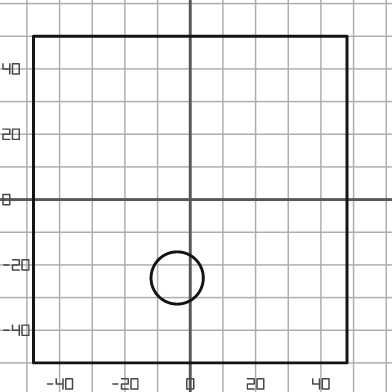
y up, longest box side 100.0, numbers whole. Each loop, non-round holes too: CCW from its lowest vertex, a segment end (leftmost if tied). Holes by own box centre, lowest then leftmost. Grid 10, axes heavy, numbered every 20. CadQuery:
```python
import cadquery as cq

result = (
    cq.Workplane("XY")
    .moveTo(-48.0, -50.0)
    .lineTo(48.0, -50.0)
    .lineTo(48.0, 50.0)
    .lineTo(-48.0, 50.0)
    .close()
    .moveTo(-4.0, -24.0)
    .circle(8.0)
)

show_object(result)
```